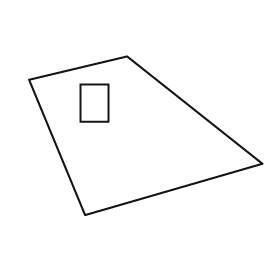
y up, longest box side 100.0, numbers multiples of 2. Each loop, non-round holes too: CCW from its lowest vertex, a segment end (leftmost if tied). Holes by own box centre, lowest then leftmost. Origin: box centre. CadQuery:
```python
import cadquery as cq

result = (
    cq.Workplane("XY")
    .moveTo(-26.0, -34.0)
    .lineTo(50.0, -12.0)
    .lineTo(-8.0, 34.0)
    .lineTo(-50.0, 24.0)
    .close()
    .moveTo(-28.0, 6.0)
    .lineTo(-16.0, 6.0)
    .lineTo(-16.0, 22.0)
    .lineTo(-28.0, 22.0)
    .close()
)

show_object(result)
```